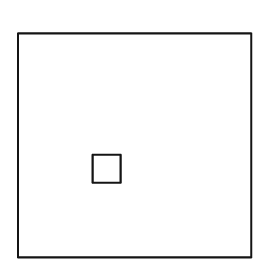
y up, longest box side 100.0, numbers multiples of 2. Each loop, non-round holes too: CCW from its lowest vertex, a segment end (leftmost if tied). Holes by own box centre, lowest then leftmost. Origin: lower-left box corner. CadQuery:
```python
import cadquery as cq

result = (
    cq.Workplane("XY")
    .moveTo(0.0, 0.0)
    .lineTo(100.0, 0.0)
    .lineTo(100.0, 96.0)
    .lineTo(0.0, 96.0)
    .close()
    .moveTo(32.0, 32.0)
    .lineTo(44.0, 32.0)
    .lineTo(44.0, 44.0)
    .lineTo(32.0, 44.0)
    .close()
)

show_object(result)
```